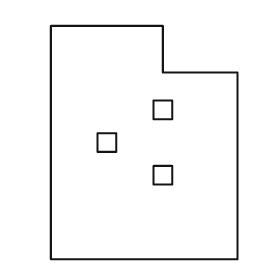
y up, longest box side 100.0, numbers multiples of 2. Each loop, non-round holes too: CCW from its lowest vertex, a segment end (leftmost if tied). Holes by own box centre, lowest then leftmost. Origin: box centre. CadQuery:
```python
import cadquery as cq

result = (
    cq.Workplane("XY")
    .moveTo(-40.0, -50.0)
    .lineTo(40.0, -50.0)
    .lineTo(40.0, 30.0)
    .lineTo(8.0, 30.0)
    .lineTo(8.0, 50.0)
    .lineTo(-40.0, 50.0)
    .close()
    .moveTo(4.0, -18.0)
    .lineTo(12.0, -18.0)
    .lineTo(12.0, -10.0)
    .lineTo(4.0, -10.0)
    .close()
    .moveTo(-20.0, -4.0)
    .lineTo(-12.0, -4.0)
    .lineTo(-12.0, 4.0)
    .lineTo(-20.0, 4.0)
    .close()
    .moveTo(4.0, 10.0)
    .lineTo(12.0, 10.0)
    .lineTo(12.0, 18.0)
    .lineTo(4.0, 18.0)
    .close()
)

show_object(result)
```